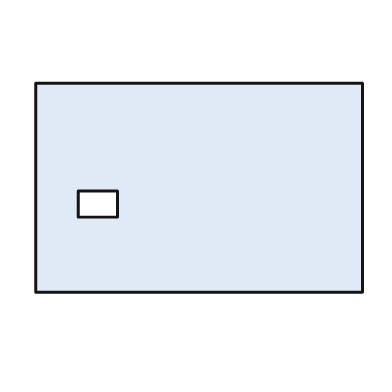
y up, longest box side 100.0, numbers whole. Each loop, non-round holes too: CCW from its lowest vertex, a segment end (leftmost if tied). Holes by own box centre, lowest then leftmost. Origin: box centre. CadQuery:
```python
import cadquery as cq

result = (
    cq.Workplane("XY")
    .moveTo(-50.0, -32.0)
    .lineTo(50.0, -32.0)
    .lineTo(50.0, 32.0)
    .lineTo(-50.0, 32.0)
    .close()
    .moveTo(-37.0, -9.0)
    .lineTo(-25.0, -9.0)
    .lineTo(-25.0, -1.0)
    .lineTo(-37.0, -1.0)
    .close()
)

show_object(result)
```